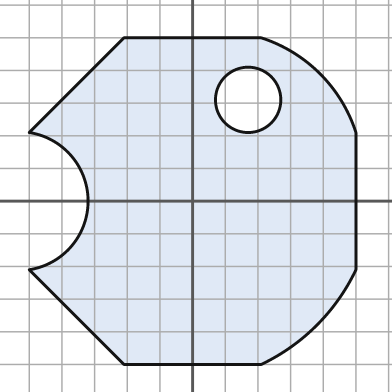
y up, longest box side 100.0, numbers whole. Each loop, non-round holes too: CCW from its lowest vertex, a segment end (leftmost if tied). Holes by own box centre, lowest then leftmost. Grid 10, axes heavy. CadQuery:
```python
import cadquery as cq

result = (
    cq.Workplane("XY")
    .moveTo(-21.0, -50.0)
    .lineTo(21.0, -50.0)
    .threePointArc((38.0, -38.0), (50.0, -21.0))
    .lineTo(50.0, 21.0)
    .threePointArc((39.0, 39.0), (21.0, 50.0))
    .lineTo(-21.0, 50.0)
    .lineTo(-50.0, 21.0)
    .threePointArc((-32.0, 0.0), (-50.0, -21.0))
    .close()
    .moveTo(17.0, 31.0)
    .circle(10.0)
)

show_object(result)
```